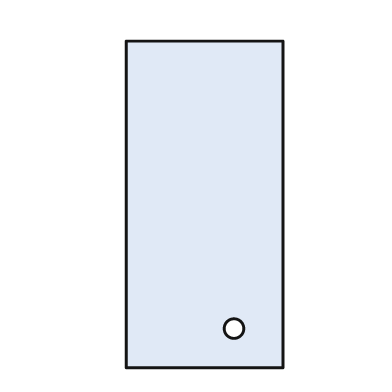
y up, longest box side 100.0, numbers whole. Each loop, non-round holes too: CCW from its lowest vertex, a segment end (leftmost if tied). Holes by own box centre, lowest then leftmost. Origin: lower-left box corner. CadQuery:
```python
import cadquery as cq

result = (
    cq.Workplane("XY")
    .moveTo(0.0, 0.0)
    .lineTo(48.0, 0.0)
    .lineTo(48.0, 100.0)
    .lineTo(0.0, 100.0)
    .close()
    .moveTo(33.0, 12.0)
    .circle(3.0)
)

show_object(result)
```